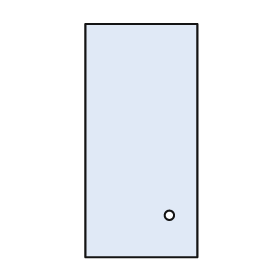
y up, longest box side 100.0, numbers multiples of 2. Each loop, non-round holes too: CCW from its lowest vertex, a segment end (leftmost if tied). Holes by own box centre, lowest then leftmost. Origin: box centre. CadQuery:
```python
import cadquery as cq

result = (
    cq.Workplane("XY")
    .moveTo(-24.0, -50.0)
    .lineTo(24.0, -50.0)
    .lineTo(24.0, 50.0)
    .lineTo(-24.0, 50.0)
    .close()
    .moveTo(12.0, -32.0)
    .circle(2.0)
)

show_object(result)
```